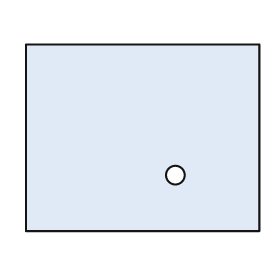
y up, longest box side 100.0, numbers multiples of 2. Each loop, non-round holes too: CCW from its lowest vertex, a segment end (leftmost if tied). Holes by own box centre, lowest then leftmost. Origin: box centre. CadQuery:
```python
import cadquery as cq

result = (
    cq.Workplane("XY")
    .moveTo(-50.0, -40.0)
    .lineTo(50.0, -40.0)
    .lineTo(50.0, 40.0)
    .lineTo(-50.0, 40.0)
    .close()
    .moveTo(14.0, -16.0)
    .circle(4.0)
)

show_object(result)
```